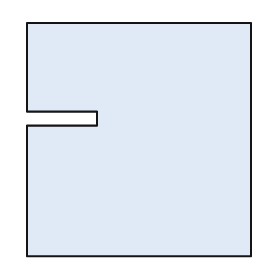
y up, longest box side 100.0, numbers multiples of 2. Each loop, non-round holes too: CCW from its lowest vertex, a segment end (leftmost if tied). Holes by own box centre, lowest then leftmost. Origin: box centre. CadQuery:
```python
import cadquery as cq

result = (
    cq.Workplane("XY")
    .moveTo(-48.0, -50.0)
    .lineTo(48.0, -50.0)
    .lineTo(48.0, 50.0)
    .lineTo(-48.0, 50.0)
    .lineTo(-48.0, 12.0)
    .lineTo(-18.0, 12.0)
    .lineTo(-18.0, 6.0)
    .lineTo(-48.0, 6.0)
    .close()
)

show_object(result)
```